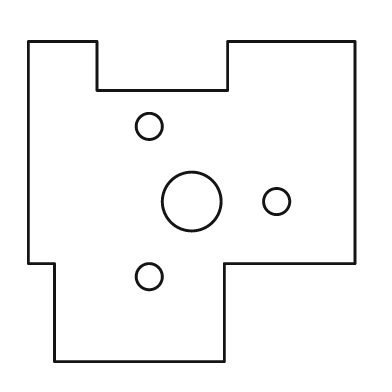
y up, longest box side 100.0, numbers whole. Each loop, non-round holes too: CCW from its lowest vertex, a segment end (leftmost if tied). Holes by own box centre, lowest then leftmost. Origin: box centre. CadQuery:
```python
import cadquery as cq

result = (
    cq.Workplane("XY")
    .moveTo(-42.0, -49.0)
    .lineTo(10.0, -49.0)
    .lineTo(10.0, -19.0)
    .lineTo(50.0, -19.0)
    .lineTo(50.0, 49.0)
    .lineTo(11.0, 49.0)
    .lineTo(11.0, 34.0)
    .lineTo(-29.0, 34.0)
    .lineTo(-29.0, 49.0)
    .lineTo(-50.0, 49.0)
    .lineTo(-50.0, -19.0)
    .lineTo(-42.0, -19.0)
    .close()
    .moveTo(-13.0, -23.0)
    .circle(4.0)
    .moveTo(0.0, 0.0)
    .circle(9.0)
    .moveTo(26.0, 0.0)
    .circle(4.0)
    .moveTo(-13.0, 23.0)
    .circle(4.0)
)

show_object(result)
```